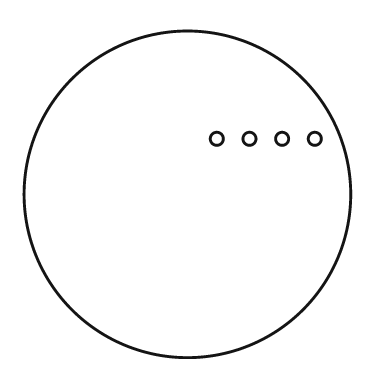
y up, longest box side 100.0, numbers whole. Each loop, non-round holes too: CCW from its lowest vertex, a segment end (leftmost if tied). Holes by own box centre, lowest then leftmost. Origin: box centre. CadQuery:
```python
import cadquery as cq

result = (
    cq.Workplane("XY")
    .moveTo(0.0, 0.0)
    .circle(50.0)
    .moveTo(9.0, 17.0)
    .circle(2.0)
    .moveTo(19.0, 17.0)
    .circle(2.0)
    .moveTo(29.0, 17.0)
    .circle(2.0)
    .moveTo(39.0, 17.0)
    .circle(2.0)
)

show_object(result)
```